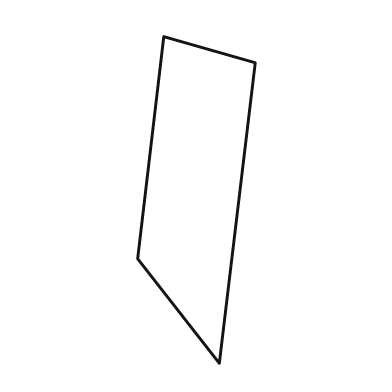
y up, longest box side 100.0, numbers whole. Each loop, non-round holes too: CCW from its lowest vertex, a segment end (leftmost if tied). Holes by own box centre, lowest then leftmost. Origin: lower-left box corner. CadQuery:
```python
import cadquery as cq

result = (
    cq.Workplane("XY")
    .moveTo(25.0, 0.0)
    .lineTo(36.0, 92.0)
    .lineTo(8.0, 100.0)
    .lineTo(0.0, 32.0)
    .close()
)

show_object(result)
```